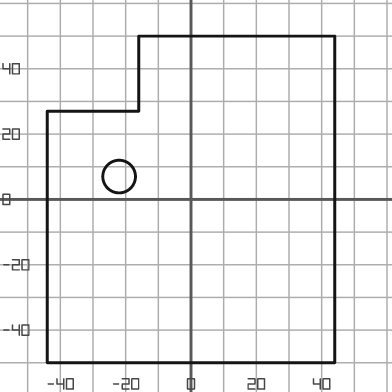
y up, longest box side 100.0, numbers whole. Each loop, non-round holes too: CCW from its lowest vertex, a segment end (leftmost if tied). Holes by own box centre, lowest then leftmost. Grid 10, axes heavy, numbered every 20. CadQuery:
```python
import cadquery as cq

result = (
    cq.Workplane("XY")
    .moveTo(-44.0, -50.0)
    .lineTo(44.0, -50.0)
    .lineTo(44.0, 50.0)
    .lineTo(-16.0, 50.0)
    .lineTo(-16.0, 27.0)
    .lineTo(-44.0, 27.0)
    .close()
    .moveTo(-22.0, 7.0)
    .circle(5.0)
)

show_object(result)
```